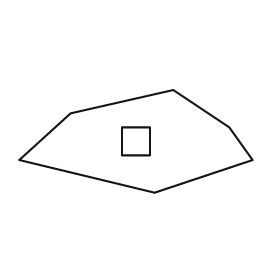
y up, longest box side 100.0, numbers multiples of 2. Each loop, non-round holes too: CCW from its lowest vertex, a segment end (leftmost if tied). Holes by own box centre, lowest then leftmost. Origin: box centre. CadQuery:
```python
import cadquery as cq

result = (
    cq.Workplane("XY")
    .moveTo(8.0, -22.0)
    .lineTo(50.0, -8.0)
    .lineTo(40.0, 6.0)
    .lineTo(16.0, 22.0)
    .lineTo(-28.0, 12.0)
    .lineTo(-50.0, -8.0)
    .close()
    .moveTo(-6.0, -6.0)
    .lineTo(6.0, -6.0)
    .lineTo(6.0, 6.0)
    .lineTo(-6.0, 6.0)
    .close()
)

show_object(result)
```